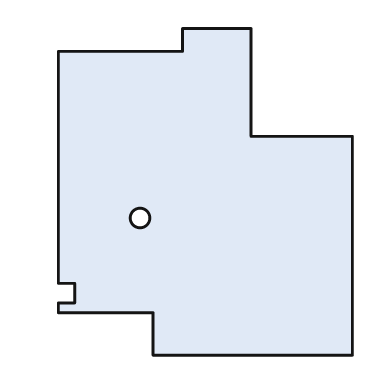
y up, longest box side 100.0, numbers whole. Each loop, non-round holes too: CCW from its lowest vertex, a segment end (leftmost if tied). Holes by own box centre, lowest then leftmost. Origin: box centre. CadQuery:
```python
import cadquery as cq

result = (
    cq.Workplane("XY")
    .moveTo(-16.0, -50.0)
    .lineTo(45.0, -50.0)
    .lineTo(45.0, 17.0)
    .lineTo(14.0, 17.0)
    .lineTo(14.0, 50.0)
    .lineTo(-7.0, 50.0)
    .lineTo(-7.0, 43.0)
    .lineTo(-45.0, 43.0)
    .lineTo(-45.0, -28.0)
    .lineTo(-40.0, -28.0)
    .lineTo(-40.0, -34.0)
    .lineTo(-45.0, -34.0)
    .lineTo(-45.0, -37.0)
    .lineTo(-16.0, -37.0)
    .close()
    .moveTo(-20.0, -8.0)
    .circle(3.0)
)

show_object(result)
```